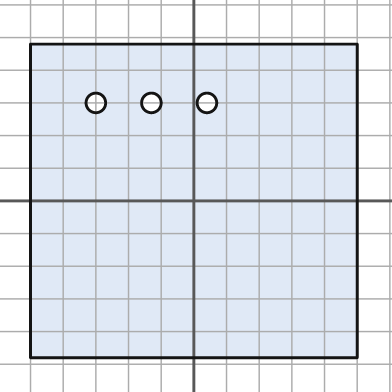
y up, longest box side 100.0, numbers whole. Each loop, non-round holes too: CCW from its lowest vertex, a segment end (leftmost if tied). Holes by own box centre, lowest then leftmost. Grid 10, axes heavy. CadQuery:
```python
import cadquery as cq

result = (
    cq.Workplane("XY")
    .moveTo(-50.0, -48.0)
    .lineTo(50.0, -48.0)
    .lineTo(50.0, 48.0)
    .lineTo(-50.0, 48.0)
    .close()
    .moveTo(-30.0, 30.0)
    .circle(3.0)
    .moveTo(-13.0, 30.0)
    .circle(3.0)
    .moveTo(4.0, 30.0)
    .circle(3.0)
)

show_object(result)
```